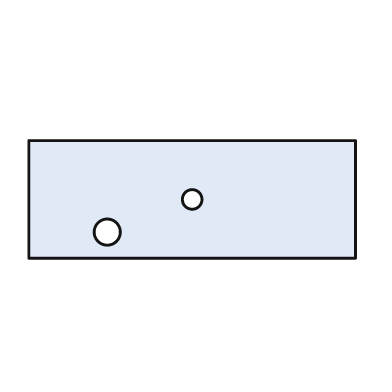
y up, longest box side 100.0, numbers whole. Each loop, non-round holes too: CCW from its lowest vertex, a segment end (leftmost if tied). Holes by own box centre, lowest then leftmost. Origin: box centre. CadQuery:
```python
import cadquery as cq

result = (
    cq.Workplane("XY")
    .moveTo(-50.0, -18.0)
    .lineTo(50.0, -18.0)
    .lineTo(50.0, 18.0)
    .lineTo(-50.0, 18.0)
    .close()
    .moveTo(-26.0, -10.0)
    .circle(4.0)
    .moveTo(0.0, 0.0)
    .circle(3.0)
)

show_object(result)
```